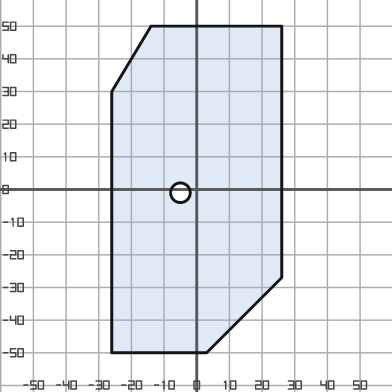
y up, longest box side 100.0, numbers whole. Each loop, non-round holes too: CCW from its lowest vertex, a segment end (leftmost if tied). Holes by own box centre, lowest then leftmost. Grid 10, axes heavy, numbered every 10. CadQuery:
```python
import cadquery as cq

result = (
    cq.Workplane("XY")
    .moveTo(-26.0, -50.0)
    .lineTo(3.0, -50.0)
    .lineTo(26.0, -27.0)
    .lineTo(26.0, 50.0)
    .lineTo(-14.0, 50.0)
    .lineTo(-26.0, 30.0)
    .close()
    .moveTo(-5.0, -1.0)
    .circle(3.0)
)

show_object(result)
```